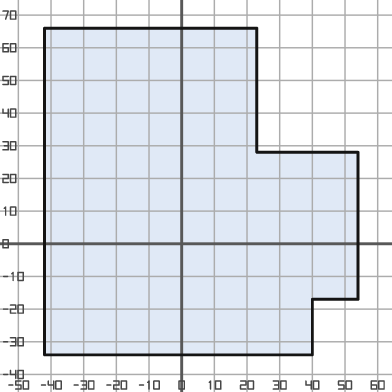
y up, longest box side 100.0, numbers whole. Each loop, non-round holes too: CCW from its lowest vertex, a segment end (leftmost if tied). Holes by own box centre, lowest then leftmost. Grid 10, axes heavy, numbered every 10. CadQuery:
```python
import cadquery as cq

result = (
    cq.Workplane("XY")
    .moveTo(-42.0, -34.0)
    .lineTo(40.0, -34.0)
    .lineTo(40.0, -17.0)
    .lineTo(54.0, -17.0)
    .lineTo(54.0, 28.0)
    .lineTo(23.0, 28.0)
    .lineTo(23.0, 66.0)
    .lineTo(-42.0, 66.0)
    .close()
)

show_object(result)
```